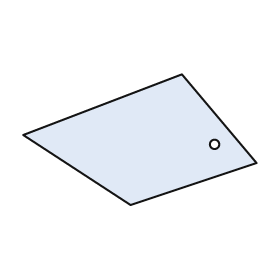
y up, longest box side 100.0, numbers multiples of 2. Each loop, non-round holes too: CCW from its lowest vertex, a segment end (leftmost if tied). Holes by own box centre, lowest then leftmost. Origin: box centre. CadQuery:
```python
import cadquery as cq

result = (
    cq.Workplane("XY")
    .moveTo(-4.0, -28.0)
    .lineTo(50.0, -10.0)
    .lineTo(18.0, 28.0)
    .lineTo(-50.0, 2.0)
    .close()
    .moveTo(32.0, -2.0)
    .circle(2.0)
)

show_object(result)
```